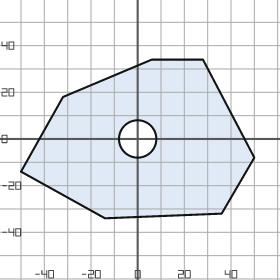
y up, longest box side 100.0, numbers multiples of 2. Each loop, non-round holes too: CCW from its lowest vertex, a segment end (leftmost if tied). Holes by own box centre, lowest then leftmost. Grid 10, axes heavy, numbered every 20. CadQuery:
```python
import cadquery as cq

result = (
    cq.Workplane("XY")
    .moveTo(-14.0, -34.0)
    .lineTo(36.0, -32.0)
    .lineTo(50.0, -8.0)
    .lineTo(28.0, 34.0)
    .lineTo(6.0, 34.0)
    .lineTo(-32.0, 18.0)
    .lineTo(-50.0, -14.0)
    .close()
    .moveTo(0.0, 0.0)
    .circle(8.0)
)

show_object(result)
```